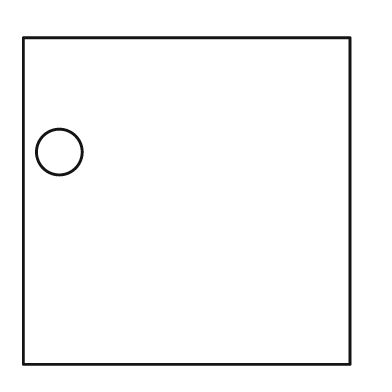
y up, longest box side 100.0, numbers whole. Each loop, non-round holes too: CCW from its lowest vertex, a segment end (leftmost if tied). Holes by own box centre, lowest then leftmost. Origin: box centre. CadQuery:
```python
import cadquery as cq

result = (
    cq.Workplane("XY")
    .moveTo(-50.0, -50.0)
    .lineTo(50.0, -50.0)
    .lineTo(50.0, 50.0)
    .lineTo(-50.0, 50.0)
    .close()
    .moveTo(-39.0, 15.0)
    .circle(7.0)
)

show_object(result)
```